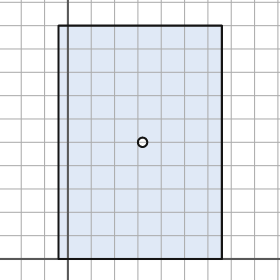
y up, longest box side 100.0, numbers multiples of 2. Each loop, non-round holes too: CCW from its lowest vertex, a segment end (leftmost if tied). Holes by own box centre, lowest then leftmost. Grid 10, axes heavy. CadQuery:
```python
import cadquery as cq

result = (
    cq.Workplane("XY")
    .moveTo(-4.0, 0.0)
    .lineTo(66.0, 0.0)
    .lineTo(66.0, 100.0)
    .lineTo(-4.0, 100.0)
    .close()
    .moveTo(32.0, 50.0)
    .circle(2.0)
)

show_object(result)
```